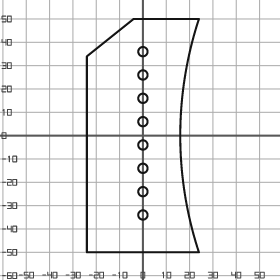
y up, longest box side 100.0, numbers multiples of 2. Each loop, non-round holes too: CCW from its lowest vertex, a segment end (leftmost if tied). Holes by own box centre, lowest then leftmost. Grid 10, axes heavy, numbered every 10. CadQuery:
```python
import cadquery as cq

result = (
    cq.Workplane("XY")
    .moveTo(-24.0, -50.0)
    .lineTo(24.0, -50.0)
    .threePointArc((16.0, 0.0), (24.0, 50.0))
    .lineTo(-4.0, 50.0)
    .lineTo(-24.0, 34.0)
    .close()
    .moveTo(0.0, -34.0)
    .circle(2.0)
    .moveTo(0.0, -24.0)
    .circle(2.0)
    .moveTo(0.0, -14.0)
    .circle(2.0)
    .moveTo(0.0, -4.0)
    .circle(2.0)
    .moveTo(0.0, 6.0)
    .circle(2.0)
    .moveTo(0.0, 16.0)
    .circle(2.0)
    .moveTo(0.0, 26.0)
    .circle(2.0)
    .moveTo(0.0, 36.0)
    .circle(2.0)
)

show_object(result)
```